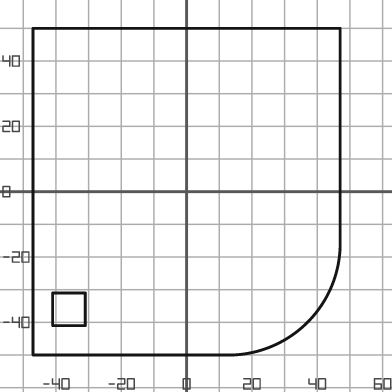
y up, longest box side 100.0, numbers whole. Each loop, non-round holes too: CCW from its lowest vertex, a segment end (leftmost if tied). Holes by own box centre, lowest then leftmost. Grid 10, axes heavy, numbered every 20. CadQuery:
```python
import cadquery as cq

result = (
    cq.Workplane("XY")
    .moveTo(-47.0, -50.0)
    .lineTo(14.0, -50.0)
    .threePointArc((37.0, -40.0), (47.0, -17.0))
    .lineTo(47.0, 50.0)
    .lineTo(-47.0, 50.0)
    .close()
    .moveTo(-41.0, -41.0)
    .lineTo(-31.0, -41.0)
    .lineTo(-31.0, -31.0)
    .lineTo(-41.0, -31.0)
    .close()
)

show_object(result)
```